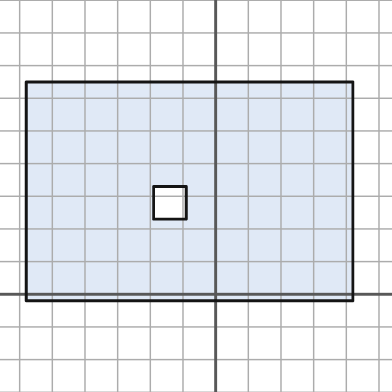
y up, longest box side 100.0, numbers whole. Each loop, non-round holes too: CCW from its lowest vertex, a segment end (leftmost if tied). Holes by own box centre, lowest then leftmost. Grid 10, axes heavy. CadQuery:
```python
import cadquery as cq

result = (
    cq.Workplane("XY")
    .moveTo(-58.0, -2.0)
    .lineTo(42.0, -2.0)
    .lineTo(42.0, 65.0)
    .lineTo(-58.0, 65.0)
    .close()
    .moveTo(-19.0, 23.0)
    .lineTo(-9.0, 23.0)
    .lineTo(-9.0, 33.0)
    .lineTo(-19.0, 33.0)
    .close()
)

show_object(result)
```